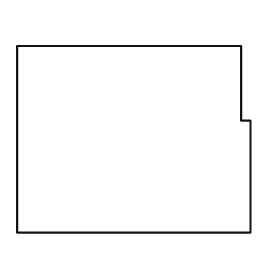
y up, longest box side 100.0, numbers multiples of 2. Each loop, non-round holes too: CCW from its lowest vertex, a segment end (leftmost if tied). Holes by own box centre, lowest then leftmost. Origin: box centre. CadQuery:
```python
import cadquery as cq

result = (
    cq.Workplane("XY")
    .moveTo(-50.0, -40.0)
    .lineTo(50.0, -40.0)
    .lineTo(50.0, 8.0)
    .lineTo(46.0, 8.0)
    .lineTo(46.0, 40.0)
    .lineTo(-50.0, 40.0)
    .close()
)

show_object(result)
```